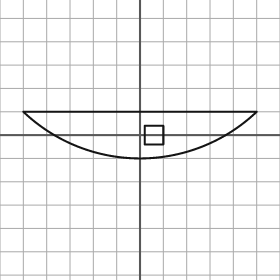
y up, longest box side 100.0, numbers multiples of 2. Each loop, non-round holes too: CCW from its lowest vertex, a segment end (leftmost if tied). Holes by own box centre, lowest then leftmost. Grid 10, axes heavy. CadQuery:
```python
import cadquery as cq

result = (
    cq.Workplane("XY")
    .moveTo(-50.0, 10.0)
    .threePointArc((0.0, -10.0), (50.0, 10.0))
    .close()
    .moveTo(2.0, -4.0)
    .lineTo(10.0, -4.0)
    .lineTo(10.0, 4.0)
    .lineTo(2.0, 4.0)
    .close()
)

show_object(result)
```